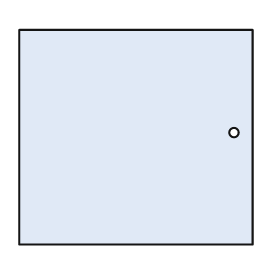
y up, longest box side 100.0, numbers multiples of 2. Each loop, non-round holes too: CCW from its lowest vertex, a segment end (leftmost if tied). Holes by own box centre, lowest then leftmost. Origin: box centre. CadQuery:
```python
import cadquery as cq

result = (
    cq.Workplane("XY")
    .moveTo(-50.0, -46.0)
    .lineTo(50.0, -46.0)
    .lineTo(50.0, 46.0)
    .lineTo(-50.0, 46.0)
    .close()
    .moveTo(42.0, 2.0)
    .circle(2.0)
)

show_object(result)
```